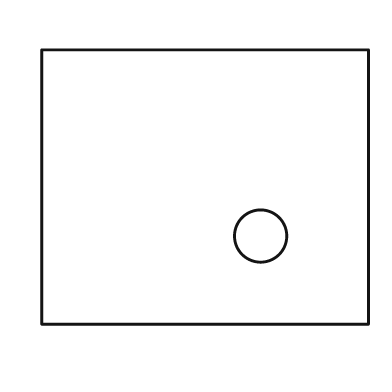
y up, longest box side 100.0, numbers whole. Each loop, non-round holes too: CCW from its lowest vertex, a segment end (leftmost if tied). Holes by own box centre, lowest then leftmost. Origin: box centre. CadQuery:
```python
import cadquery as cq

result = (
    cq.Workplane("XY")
    .moveTo(-50.0, -42.0)
    .lineTo(50.0, -42.0)
    .lineTo(50.0, 42.0)
    .lineTo(-50.0, 42.0)
    .close()
    .moveTo(17.0, -15.0)
    .circle(8.0)
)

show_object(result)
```